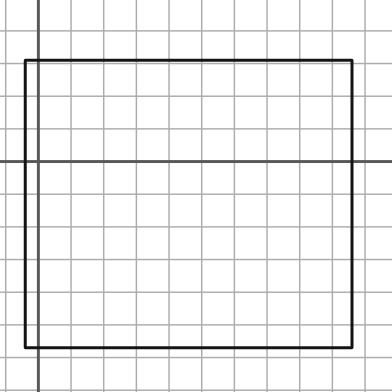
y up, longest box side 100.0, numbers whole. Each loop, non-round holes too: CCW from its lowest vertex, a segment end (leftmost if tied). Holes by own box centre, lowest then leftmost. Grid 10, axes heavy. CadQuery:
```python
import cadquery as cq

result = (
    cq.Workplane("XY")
    .moveTo(-4.0, -57.0)
    .lineTo(96.0, -57.0)
    .lineTo(96.0, 31.0)
    .lineTo(-4.0, 31.0)
    .close()
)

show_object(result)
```